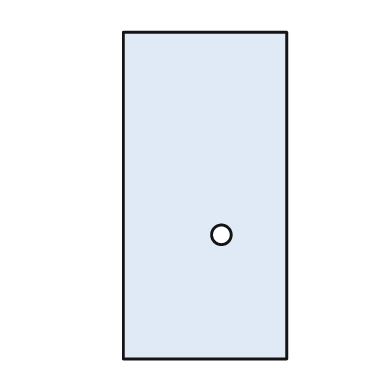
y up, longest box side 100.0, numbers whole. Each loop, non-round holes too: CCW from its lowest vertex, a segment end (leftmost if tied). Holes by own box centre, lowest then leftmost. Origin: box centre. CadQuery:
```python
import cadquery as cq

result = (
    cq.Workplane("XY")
    .moveTo(-25.0, -50.0)
    .lineTo(25.0, -50.0)
    .lineTo(25.0, 50.0)
    .lineTo(-25.0, 50.0)
    .close()
    .moveTo(5.0, -12.0)
    .circle(3.0)
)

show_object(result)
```